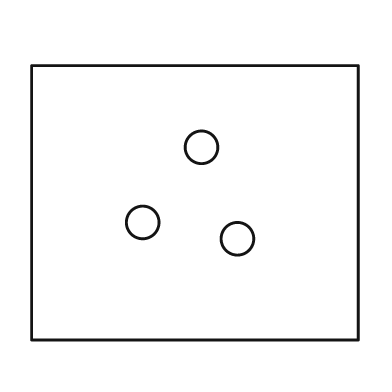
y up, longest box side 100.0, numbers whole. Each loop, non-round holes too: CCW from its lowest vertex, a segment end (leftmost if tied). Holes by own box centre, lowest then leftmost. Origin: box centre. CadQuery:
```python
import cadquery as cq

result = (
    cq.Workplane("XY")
    .moveTo(-50.0, -42.0)
    .lineTo(50.0, -42.0)
    .lineTo(50.0, 42.0)
    .lineTo(-50.0, 42.0)
    .close()
    .moveTo(13.0, -11.0)
    .circle(5.0)
    .moveTo(-16.0, -6.0)
    .circle(5.0)
    .moveTo(2.0, 17.0)
    .circle(5.0)
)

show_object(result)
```